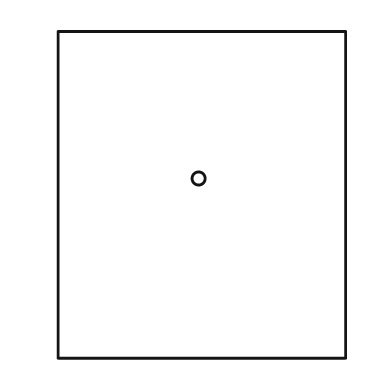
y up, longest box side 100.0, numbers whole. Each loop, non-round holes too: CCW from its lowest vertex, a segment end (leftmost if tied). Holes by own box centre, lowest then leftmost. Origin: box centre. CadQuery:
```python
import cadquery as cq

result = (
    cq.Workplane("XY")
    .moveTo(-44.0, -50.0)
    .lineTo(44.0, -50.0)
    .lineTo(44.0, 50.0)
    .lineTo(-44.0, 50.0)
    .close()
    .moveTo(-1.0, 5.0)
    .circle(2.0)
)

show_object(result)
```